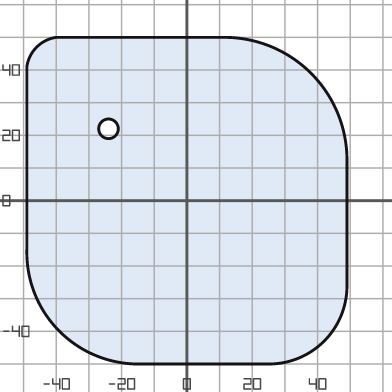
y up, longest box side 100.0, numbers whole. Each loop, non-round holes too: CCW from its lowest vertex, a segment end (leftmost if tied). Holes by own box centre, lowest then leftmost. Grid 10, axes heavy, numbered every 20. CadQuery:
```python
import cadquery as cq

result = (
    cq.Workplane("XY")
    .moveTo(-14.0, -50.0)
    .lineTo(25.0, -50.0)
    .threePointArc((42.0, -43.0), (49.0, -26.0))
    .lineTo(49.0, 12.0)
    .threePointArc((38.0, 39.0), (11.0, 50.0))
    .lineTo(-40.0, 50.0)
    .threePointArc((-46.0, 47.0), (-49.0, 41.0))
    .lineTo(-49.0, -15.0)
    .threePointArc((-39.0, -40.0), (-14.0, -50.0))
    .close()
    .moveTo(-24.0, 22.0)
    .circle(3.0)
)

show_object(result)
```